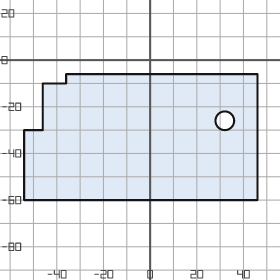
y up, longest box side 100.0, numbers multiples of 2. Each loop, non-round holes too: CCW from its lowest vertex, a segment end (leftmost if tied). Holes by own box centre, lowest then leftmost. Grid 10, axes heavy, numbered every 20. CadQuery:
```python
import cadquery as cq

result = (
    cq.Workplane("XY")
    .moveTo(-54.0, -60.0)
    .lineTo(46.0, -60.0)
    .lineTo(46.0, -6.0)
    .lineTo(-36.0, -6.0)
    .lineTo(-36.0, -10.0)
    .lineTo(-46.0, -10.0)
    .lineTo(-46.0, -30.0)
    .lineTo(-54.0, -30.0)
    .close()
    .moveTo(32.0, -26.0)
    .circle(4.0)
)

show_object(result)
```